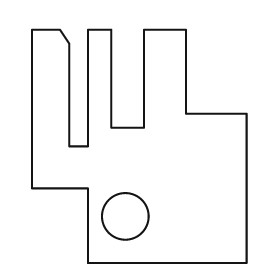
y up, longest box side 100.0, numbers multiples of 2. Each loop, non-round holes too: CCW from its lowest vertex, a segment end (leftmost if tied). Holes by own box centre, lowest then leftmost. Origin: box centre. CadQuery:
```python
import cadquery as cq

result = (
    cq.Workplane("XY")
    .moveTo(-22.0, -50.0)
    .lineTo(46.0, -50.0)
    .lineTo(46.0, 14.0)
    .lineTo(20.0, 14.0)
    .lineTo(20.0, 50.0)
    .lineTo(2.0, 50.0)
    .lineTo(2.0, 8.0)
    .lineTo(-12.0, 8.0)
    .lineTo(-12.0, 50.0)
    .lineTo(-22.0, 50.0)
    .lineTo(-22.0, 0.0)
    .lineTo(-30.0, 0.0)
    .lineTo(-30.0, 44.0)
    .lineTo(-34.0, 50.0)
    .lineTo(-46.0, 50.0)
    .lineTo(-46.0, -18.0)
    .lineTo(-22.0, -18.0)
    .close()
    .moveTo(-6.0, -30.0)
    .circle(10.0)
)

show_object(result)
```